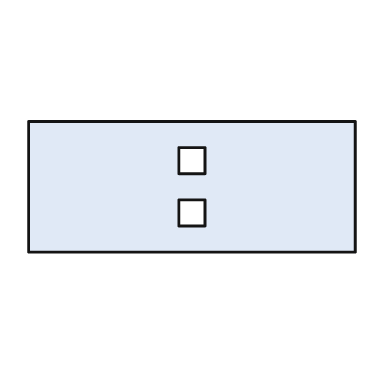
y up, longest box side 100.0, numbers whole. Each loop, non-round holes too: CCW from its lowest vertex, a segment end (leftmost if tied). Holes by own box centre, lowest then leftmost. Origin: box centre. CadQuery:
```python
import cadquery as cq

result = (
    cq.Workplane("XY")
    .moveTo(-50.0, -20.0)
    .lineTo(50.0, -20.0)
    .lineTo(50.0, 20.0)
    .lineTo(-50.0, 20.0)
    .close()
    .moveTo(-4.0, -12.0)
    .lineTo(4.0, -12.0)
    .lineTo(4.0, -4.0)
    .lineTo(-4.0, -4.0)
    .close()
    .moveTo(-4.0, 4.0)
    .lineTo(4.0, 4.0)
    .lineTo(4.0, 12.0)
    .lineTo(-4.0, 12.0)
    .close()
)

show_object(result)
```